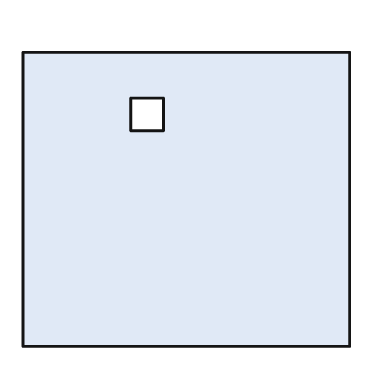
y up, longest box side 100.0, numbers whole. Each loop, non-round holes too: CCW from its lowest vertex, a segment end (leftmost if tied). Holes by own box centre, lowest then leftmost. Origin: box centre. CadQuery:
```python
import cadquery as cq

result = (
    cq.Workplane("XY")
    .moveTo(-50.0, -45.0)
    .lineTo(50.0, -45.0)
    .lineTo(50.0, 45.0)
    .lineTo(-50.0, 45.0)
    .close()
    .moveTo(-17.0, 21.0)
    .lineTo(-7.0, 21.0)
    .lineTo(-7.0, 31.0)
    .lineTo(-17.0, 31.0)
    .close()
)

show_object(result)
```